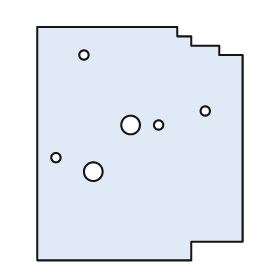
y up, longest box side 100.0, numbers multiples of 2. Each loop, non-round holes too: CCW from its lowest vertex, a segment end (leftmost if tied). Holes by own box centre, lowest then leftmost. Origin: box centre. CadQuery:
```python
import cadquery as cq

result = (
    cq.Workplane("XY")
    .moveTo(-44.0, -50.0)
    .lineTo(22.0, -50.0)
    .lineTo(22.0, -42.0)
    .lineTo(44.0, -42.0)
    .lineTo(44.0, 38.0)
    .lineTo(34.0, 38.0)
    .lineTo(34.0, 42.0)
    .lineTo(22.0, 42.0)
    .lineTo(22.0, 46.0)
    .lineTo(16.0, 46.0)
    .lineTo(16.0, 50.0)
    .lineTo(-44.0, 50.0)
    .close()
    .moveTo(-20.0, -12.0)
    .circle(4.0)
    .moveTo(-36.0, -6.0)
    .circle(2.0)
    .moveTo(-4.0, 8.0)
    .circle(4.0)
    .moveTo(8.0, 8.0)
    .circle(2.0)
    .moveTo(28.0, 14.0)
    .circle(2.0)
    .moveTo(-24.0, 38.0)
    .circle(2.0)
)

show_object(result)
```